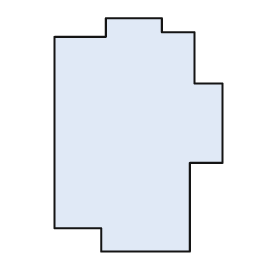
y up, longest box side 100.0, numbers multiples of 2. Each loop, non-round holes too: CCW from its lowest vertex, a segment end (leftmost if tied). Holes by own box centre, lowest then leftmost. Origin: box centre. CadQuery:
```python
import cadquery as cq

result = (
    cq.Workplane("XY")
    .moveTo(-16.0, -50.0)
    .lineTo(22.0, -50.0)
    .lineTo(22.0, -12.0)
    .lineTo(36.0, -12.0)
    .lineTo(36.0, 22.0)
    .lineTo(24.0, 22.0)
    .lineTo(24.0, 44.0)
    .lineTo(10.0, 44.0)
    .lineTo(10.0, 50.0)
    .lineTo(-14.0, 50.0)
    .lineTo(-14.0, 42.0)
    .lineTo(-36.0, 42.0)
    .lineTo(-36.0, -40.0)
    .lineTo(-16.0, -40.0)
    .close()
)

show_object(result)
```